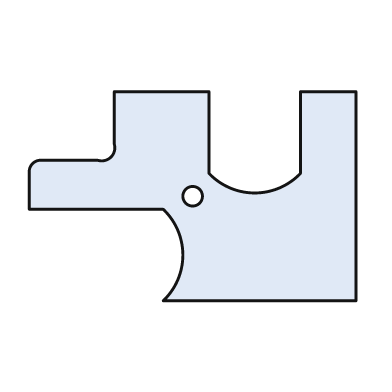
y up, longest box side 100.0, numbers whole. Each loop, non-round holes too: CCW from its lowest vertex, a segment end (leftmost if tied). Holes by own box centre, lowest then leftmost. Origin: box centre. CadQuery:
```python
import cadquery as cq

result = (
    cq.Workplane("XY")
    .moveTo(-9.0, -32.0)
    .lineTo(50.0, -32.0)
    .lineTo(50.0, 32.0)
    .lineTo(33.0, 32.0)
    .lineTo(33.0, 7.0)
    .threePointArc((19.0, 1.0), (5.0, 7.0))
    .lineTo(5.0, 32.0)
    .lineTo(-24.0, 32.0)
    .lineTo(-24.0, 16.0)
    .threePointArc((-25.0, 12.0), (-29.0, 11.0))
    .lineTo(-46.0, 11.0)
    .threePointArc((-49.0, 10.0), (-50.0, 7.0))
    .lineTo(-50.0, -4.0)
    .lineTo(-9.0, -4.0)
    .threePointArc((-3.0, -18.0), (-9.0, -32.0))
    .close()
    .moveTo(0.0, 0.0)
    .circle(3.0)
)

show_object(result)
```